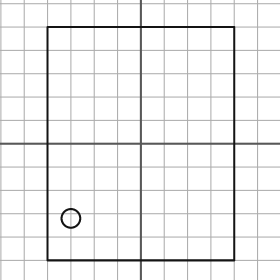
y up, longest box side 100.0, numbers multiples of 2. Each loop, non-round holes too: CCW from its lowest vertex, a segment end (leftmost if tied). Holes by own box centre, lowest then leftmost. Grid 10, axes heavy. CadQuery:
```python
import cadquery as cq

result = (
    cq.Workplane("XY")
    .moveTo(-40.0, -50.0)
    .lineTo(40.0, -50.0)
    .lineTo(40.0, 50.0)
    .lineTo(-40.0, 50.0)
    .close()
    .moveTo(-30.0, -32.0)
    .circle(4.0)
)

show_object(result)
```